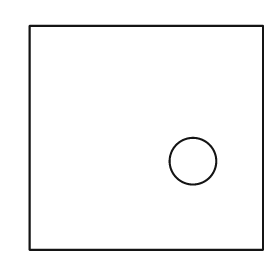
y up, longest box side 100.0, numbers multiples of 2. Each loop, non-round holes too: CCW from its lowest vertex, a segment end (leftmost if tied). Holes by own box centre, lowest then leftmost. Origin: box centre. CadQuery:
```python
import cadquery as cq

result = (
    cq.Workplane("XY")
    .moveTo(-50.0, -48.0)
    .lineTo(50.0, -48.0)
    .lineTo(50.0, 48.0)
    .lineTo(-50.0, 48.0)
    .close()
    .moveTo(20.0, -10.0)
    .circle(10.0)
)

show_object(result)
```